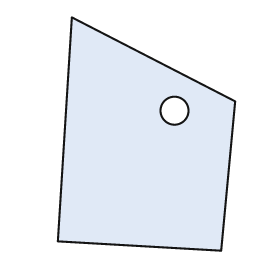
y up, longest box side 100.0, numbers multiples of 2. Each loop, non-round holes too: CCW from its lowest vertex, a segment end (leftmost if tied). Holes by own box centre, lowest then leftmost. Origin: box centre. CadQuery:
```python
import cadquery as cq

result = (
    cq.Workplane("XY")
    .moveTo(32.0, -50.0)
    .lineTo(38.0, 14.0)
    .lineTo(-32.0, 50.0)
    .lineTo(-38.0, -46.0)
    .close()
    .moveTo(12.0, 10.0)
    .circle(6.0)
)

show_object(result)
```